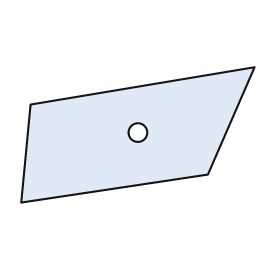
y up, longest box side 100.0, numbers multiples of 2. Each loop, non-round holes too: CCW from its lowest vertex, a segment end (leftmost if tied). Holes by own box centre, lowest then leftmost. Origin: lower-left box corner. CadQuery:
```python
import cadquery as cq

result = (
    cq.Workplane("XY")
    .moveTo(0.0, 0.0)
    .lineTo(80.0, 12.0)
    .lineTo(100.0, 58.0)
    .lineTo(4.0, 42.0)
    .close()
    .moveTo(50.0, 30.0)
    .circle(4.0)
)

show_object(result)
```